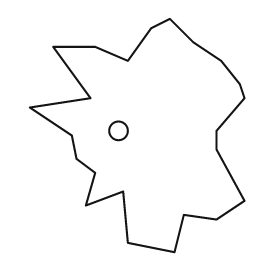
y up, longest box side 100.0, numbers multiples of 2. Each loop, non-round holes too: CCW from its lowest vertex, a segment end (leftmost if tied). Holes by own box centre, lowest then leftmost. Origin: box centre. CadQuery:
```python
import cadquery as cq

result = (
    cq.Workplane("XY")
    .moveTo(16.0, -50.0)
    .lineTo(20.0, -34.0)
    .lineTo(34.0, -36.0)
    .lineTo(46.0, -28.0)
    .lineTo(34.0, -6.0)
    .lineTo(34.0, 2.0)
    .lineTo(46.0, 16.0)
    .lineTo(44.0, 22.0)
    .lineTo(36.0, 32.0)
    .lineTo(24.0, 40.0)
    .lineTo(14.0, 50.0)
    .lineTo(6.0, 46.0)
    .lineTo(-4.0, 32.0)
    .lineTo(-18.0, 38.0)
    .lineTo(-36.0, 38.0)
    .lineTo(-20.0, 16.0)
    .lineTo(-46.0, 12.0)
    .lineTo(-28.0, 0.0)
    .lineTo(-26.0, -10.0)
    .lineTo(-18.0, -16.0)
    .lineTo(-22.0, -30.0)
    .lineTo(-6.0, -24.0)
    .lineTo(-4.0, -46.0)
    .close()
    .moveTo(-8.0, 2.0)
    .circle(4.0)
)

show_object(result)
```